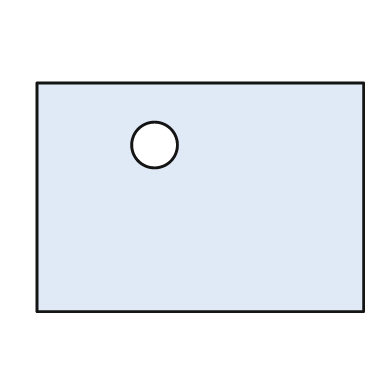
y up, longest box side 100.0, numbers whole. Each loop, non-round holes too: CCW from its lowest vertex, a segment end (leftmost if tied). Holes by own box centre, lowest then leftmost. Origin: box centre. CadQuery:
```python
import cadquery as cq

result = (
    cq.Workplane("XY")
    .moveTo(-50.0, -35.0)
    .lineTo(50.0, -35.0)
    .lineTo(50.0, 35.0)
    .lineTo(-50.0, 35.0)
    .close()
    .moveTo(-14.0, 16.0)
    .circle(7.0)
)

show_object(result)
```